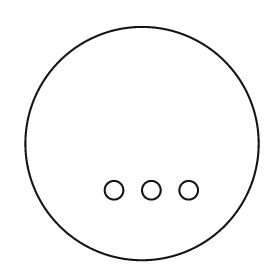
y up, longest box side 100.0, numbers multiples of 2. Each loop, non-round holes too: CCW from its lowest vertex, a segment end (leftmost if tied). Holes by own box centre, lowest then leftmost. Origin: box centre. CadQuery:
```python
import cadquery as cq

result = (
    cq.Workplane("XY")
    .moveTo(0.0, 0.0)
    .circle(50.0)
    .moveTo(-12.0, -20.0)
    .circle(4.0)
    .moveTo(4.0, -20.0)
    .circle(4.0)
    .moveTo(20.0, -20.0)
    .circle(4.0)
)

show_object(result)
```